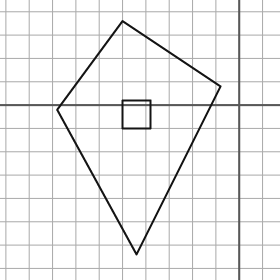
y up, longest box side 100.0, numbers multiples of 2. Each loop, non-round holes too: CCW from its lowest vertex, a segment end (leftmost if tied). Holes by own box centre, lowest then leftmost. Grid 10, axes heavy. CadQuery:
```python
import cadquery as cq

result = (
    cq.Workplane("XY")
    .moveTo(-44.0, -64.0)
    .lineTo(-8.0, 8.0)
    .lineTo(-50.0, 36.0)
    .lineTo(-78.0, -2.0)
    .close()
    .moveTo(-50.0, -10.0)
    .lineTo(-38.0, -10.0)
    .lineTo(-38.0, 2.0)
    .lineTo(-50.0, 2.0)
    .close()
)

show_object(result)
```